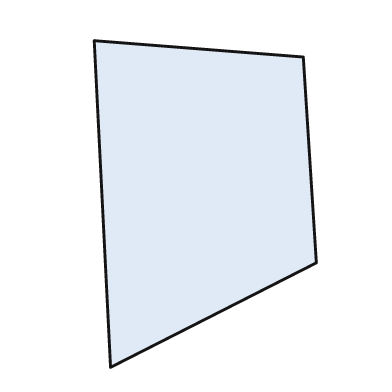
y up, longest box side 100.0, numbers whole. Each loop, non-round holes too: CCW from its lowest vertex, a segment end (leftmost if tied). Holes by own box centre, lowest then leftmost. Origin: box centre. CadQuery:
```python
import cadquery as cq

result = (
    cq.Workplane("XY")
    .moveTo(-29.0, -50.0)
    .lineTo(34.0, -18.0)
    .lineTo(30.0, 45.0)
    .lineTo(-34.0, 50.0)
    .close()
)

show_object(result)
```